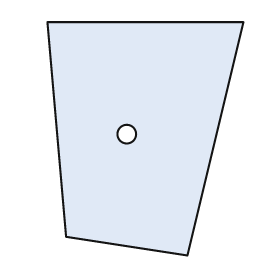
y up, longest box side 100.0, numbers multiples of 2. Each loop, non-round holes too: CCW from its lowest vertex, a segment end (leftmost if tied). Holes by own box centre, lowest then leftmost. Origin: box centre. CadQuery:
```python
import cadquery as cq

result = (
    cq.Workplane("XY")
    .moveTo(18.0, -50.0)
    .lineTo(42.0, 50.0)
    .lineTo(-42.0, 50.0)
    .lineTo(-34.0, -42.0)
    .close()
    .moveTo(-8.0, 2.0)
    .circle(4.0)
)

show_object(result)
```